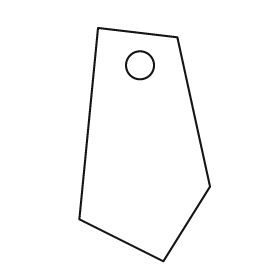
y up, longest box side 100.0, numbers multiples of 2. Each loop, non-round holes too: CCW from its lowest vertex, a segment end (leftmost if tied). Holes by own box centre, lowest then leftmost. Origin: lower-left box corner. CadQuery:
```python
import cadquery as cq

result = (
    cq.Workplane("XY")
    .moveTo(36.0, 0.0)
    .lineTo(56.0, 32.0)
    .lineTo(42.0, 96.0)
    .lineTo(8.0, 100.0)
    .lineTo(0.0, 18.0)
    .close()
    .moveTo(26.0, 84.0)
    .circle(6.0)
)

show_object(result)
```